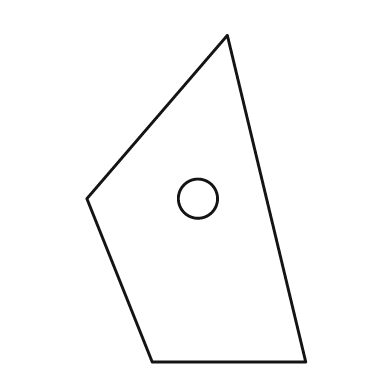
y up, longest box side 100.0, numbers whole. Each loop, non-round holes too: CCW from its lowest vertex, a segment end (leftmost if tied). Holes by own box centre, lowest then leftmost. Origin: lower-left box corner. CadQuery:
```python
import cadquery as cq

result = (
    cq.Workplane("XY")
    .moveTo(20.0, 0.0)
    .lineTo(67.0, 0.0)
    .lineTo(43.0, 100.0)
    .lineTo(0.0, 50.0)
    .close()
    .moveTo(34.0, 50.0)
    .circle(6.0)
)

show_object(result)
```